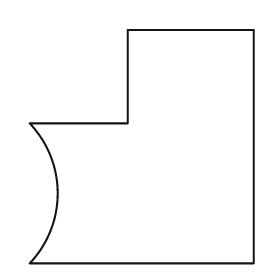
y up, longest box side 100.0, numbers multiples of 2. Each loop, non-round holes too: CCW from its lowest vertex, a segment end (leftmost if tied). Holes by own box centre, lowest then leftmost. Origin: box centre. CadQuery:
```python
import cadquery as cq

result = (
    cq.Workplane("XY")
    .moveTo(-48.0, -50.0)
    .lineTo(48.0, -50.0)
    .lineTo(48.0, 50.0)
    .lineTo(-6.0, 50.0)
    .lineTo(-6.0, 10.0)
    .lineTo(-48.0, 10.0)
    .threePointArc((-36.0, -20.0), (-48.0, -50.0))
    .close()
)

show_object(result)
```